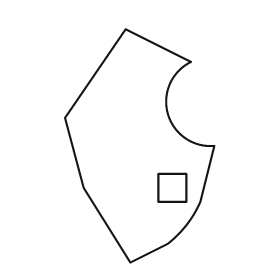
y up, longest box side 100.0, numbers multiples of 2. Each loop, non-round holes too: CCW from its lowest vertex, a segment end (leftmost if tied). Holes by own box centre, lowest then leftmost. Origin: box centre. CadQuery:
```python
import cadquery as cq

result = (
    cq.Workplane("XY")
    .moveTo(-4.0, -50.0)
    .lineTo(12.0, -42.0)
    .threePointArc((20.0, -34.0), (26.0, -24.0))
    .lineTo(32.0, 0.0)
    .threePointArc((12.0, 14.0), (22.0, 36.0))
    .lineTo(-6.0, 50.0)
    .lineTo(-32.0, 12.0)
    .lineTo(-24.0, -18.0)
    .close()
    .moveTo(8.0, -24.0)
    .lineTo(20.0, -24.0)
    .lineTo(20.0, -12.0)
    .lineTo(8.0, -12.0)
    .close()
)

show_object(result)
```